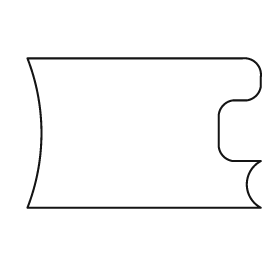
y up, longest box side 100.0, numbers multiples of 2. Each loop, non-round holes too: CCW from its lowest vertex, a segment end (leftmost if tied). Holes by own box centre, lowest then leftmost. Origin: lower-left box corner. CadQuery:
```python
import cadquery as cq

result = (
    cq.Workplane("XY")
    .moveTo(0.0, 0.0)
    .lineTo(100.0, 0.0)
    .threePointArc((94.0, 10.0), (100.0, 20.0))
    .lineTo(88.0, 20.0)
    .threePointArc((84.0, 22.0), (82.0, 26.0))
    .lineTo(82.0, 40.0)
    .threePointArc((84.0, 44.0), (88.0, 46.0))
    .lineTo(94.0, 46.0)
    .threePointArc((98.0, 48.0), (100.0, 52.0))
    .lineTo(100.0, 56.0)
    .threePointArc((98.0, 62.0), (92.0, 64.0))
    .lineTo(0.0, 64.0)
    .threePointArc((6.0, 32.0), (0.0, 0.0))
    .close()
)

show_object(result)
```